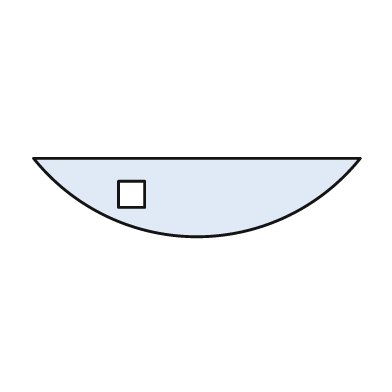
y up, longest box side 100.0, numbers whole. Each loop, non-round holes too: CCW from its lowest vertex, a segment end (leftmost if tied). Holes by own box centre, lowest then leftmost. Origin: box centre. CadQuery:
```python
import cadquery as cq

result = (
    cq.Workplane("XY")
    .moveTo(-50.0, 12.0)
    .threePointArc((0.0, -12.0), (50.0, 12.0))
    .close()
    .moveTo(-24.0, -3.0)
    .lineTo(-16.0, -3.0)
    .lineTo(-16.0, 5.0)
    .lineTo(-24.0, 5.0)
    .close()
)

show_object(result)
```